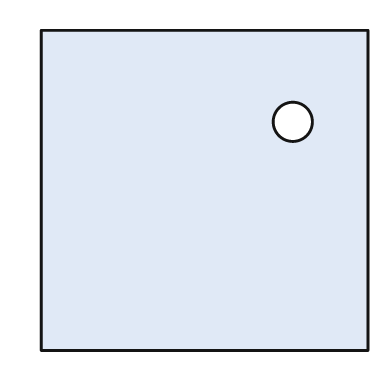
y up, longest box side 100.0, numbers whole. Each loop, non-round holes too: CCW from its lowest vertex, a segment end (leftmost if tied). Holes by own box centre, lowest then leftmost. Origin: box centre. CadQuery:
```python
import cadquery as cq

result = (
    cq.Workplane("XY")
    .moveTo(-50.0, -49.0)
    .lineTo(50.0, -49.0)
    .lineTo(50.0, 49.0)
    .lineTo(-50.0, 49.0)
    .close()
    .moveTo(27.0, 21.0)
    .circle(6.0)
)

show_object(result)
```